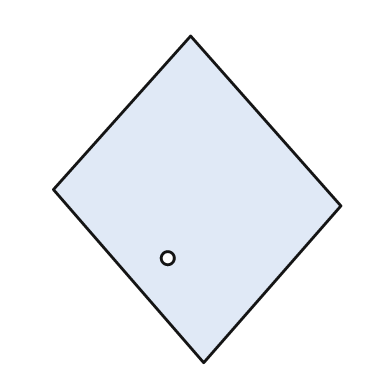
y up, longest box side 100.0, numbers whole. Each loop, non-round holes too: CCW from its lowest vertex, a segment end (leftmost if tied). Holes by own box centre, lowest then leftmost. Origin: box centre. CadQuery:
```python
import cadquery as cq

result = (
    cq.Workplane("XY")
    .moveTo(2.0, -50.0)
    .lineTo(44.0, -2.0)
    .lineTo(-2.0, 50.0)
    .lineTo(-44.0, 3.0)
    .close()
    .moveTo(-9.0, -18.0)
    .circle(2.0)
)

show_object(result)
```